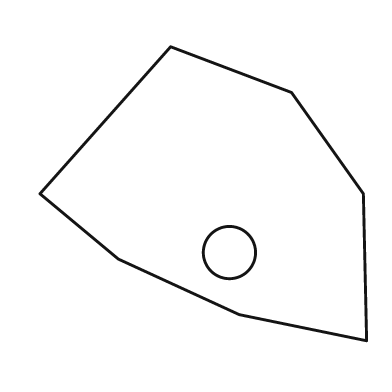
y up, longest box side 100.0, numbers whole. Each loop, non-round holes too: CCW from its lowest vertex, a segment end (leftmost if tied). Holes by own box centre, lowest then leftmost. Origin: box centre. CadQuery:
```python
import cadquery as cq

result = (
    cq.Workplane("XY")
    .moveTo(50.0, -45.0)
    .lineTo(49.0, 0.0)
    .lineTo(27.0, 31.0)
    .lineTo(-10.0, 45.0)
    .lineTo(-50.0, 0.0)
    .lineTo(-26.0, -20.0)
    .lineTo(11.0, -37.0)
    .close()
    .moveTo(8.0, -18.0)
    .circle(8.0)
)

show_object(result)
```